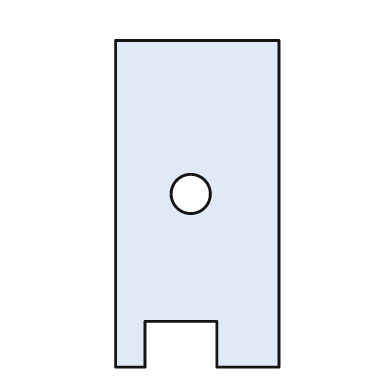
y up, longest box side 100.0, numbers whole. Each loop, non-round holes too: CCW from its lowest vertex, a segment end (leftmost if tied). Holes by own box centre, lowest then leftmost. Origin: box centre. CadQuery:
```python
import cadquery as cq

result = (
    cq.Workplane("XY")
    .moveTo(-25.0, -50.0)
    .lineTo(-16.0, -50.0)
    .lineTo(-16.0, -36.0)
    .lineTo(6.0, -36.0)
    .lineTo(6.0, -50.0)
    .lineTo(25.0, -50.0)
    .lineTo(25.0, 50.0)
    .lineTo(-25.0, 50.0)
    .close()
    .moveTo(-2.0, 3.0)
    .circle(6.0)
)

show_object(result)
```